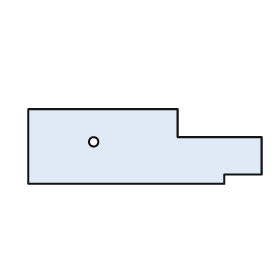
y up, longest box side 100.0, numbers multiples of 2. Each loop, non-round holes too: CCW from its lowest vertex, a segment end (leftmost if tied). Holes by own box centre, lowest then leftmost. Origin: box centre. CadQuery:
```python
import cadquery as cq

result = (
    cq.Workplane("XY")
    .moveTo(-50.0, -16.0)
    .lineTo(34.0, -16.0)
    .lineTo(34.0, -12.0)
    .lineTo(50.0, -12.0)
    .lineTo(50.0, 4.0)
    .lineTo(14.0, 4.0)
    .lineTo(14.0, 16.0)
    .lineTo(-50.0, 16.0)
    .close()
    .moveTo(-22.0, 2.0)
    .circle(2.0)
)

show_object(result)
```